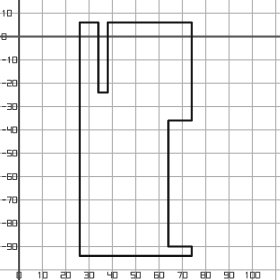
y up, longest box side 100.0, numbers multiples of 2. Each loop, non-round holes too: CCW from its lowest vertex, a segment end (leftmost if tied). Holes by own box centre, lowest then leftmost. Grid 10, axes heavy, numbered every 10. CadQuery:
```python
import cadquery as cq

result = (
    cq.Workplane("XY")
    .moveTo(26.0, -94.0)
    .lineTo(74.0, -94.0)
    .lineTo(74.0, -90.0)
    .lineTo(64.0, -90.0)
    .lineTo(64.0, -36.0)
    .lineTo(74.0, -36.0)
    .lineTo(74.0, 6.0)
    .lineTo(38.0, 6.0)
    .lineTo(38.0, -24.0)
    .lineTo(34.0, -24.0)
    .lineTo(34.0, 6.0)
    .lineTo(26.0, 6.0)
    .close()
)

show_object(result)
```